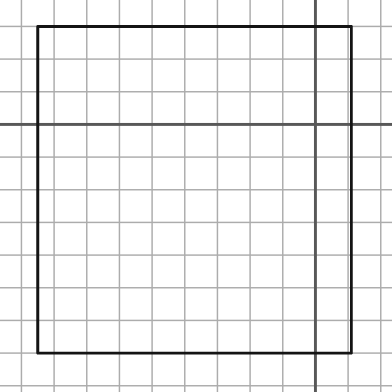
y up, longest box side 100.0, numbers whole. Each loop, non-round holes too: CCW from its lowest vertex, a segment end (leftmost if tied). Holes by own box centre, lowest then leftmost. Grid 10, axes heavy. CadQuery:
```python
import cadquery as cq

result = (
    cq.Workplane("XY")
    .moveTo(-85.0, -70.0)
    .lineTo(11.0, -70.0)
    .lineTo(11.0, 30.0)
    .lineTo(-85.0, 30.0)
    .close()
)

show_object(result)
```